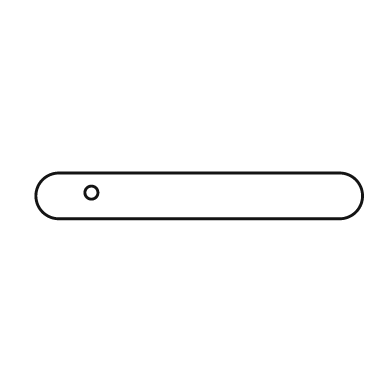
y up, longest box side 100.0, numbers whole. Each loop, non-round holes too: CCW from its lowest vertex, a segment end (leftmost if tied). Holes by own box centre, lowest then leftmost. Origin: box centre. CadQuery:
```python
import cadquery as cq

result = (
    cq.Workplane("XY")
    .moveTo(-43.0, -7.0)
    .lineTo(43.0, -7.0)
    .threePointArc((50.0, 0.0), (43.0, 7.0))
    .lineTo(-43.0, 7.0)
    .threePointArc((-50.0, 0.0), (-43.0, -7.0))
    .close()
    .moveTo(-33.0, 1.0)
    .circle(2.0)
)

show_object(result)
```